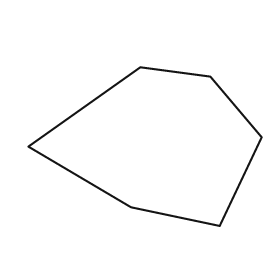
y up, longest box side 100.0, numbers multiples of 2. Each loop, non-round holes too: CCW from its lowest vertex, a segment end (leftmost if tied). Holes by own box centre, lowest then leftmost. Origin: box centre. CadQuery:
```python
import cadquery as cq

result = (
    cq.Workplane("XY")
    .moveTo(32.0, -34.0)
    .lineTo(50.0, 4.0)
    .lineTo(28.0, 30.0)
    .lineTo(-2.0, 34.0)
    .lineTo(-50.0, 0.0)
    .lineTo(-6.0, -26.0)
    .close()
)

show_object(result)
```